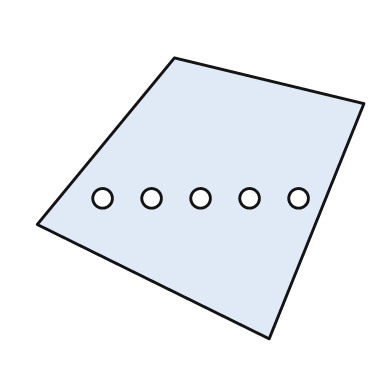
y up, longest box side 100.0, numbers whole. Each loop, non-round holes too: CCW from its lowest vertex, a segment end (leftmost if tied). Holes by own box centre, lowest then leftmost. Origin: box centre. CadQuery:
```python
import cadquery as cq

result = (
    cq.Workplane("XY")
    .moveTo(21.0, -43.0)
    .lineTo(50.0, 29.0)
    .lineTo(-8.0, 43.0)
    .lineTo(-50.0, -8.0)
    .close()
    .moveTo(-30.0, 0.0)
    .circle(3.0)
    .moveTo(-15.0, 0.0)
    .circle(3.0)
    .moveTo(0.0, 0.0)
    .circle(3.0)
    .moveTo(15.0, 0.0)
    .circle(3.0)
    .moveTo(30.0, 0.0)
    .circle(3.0)
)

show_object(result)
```